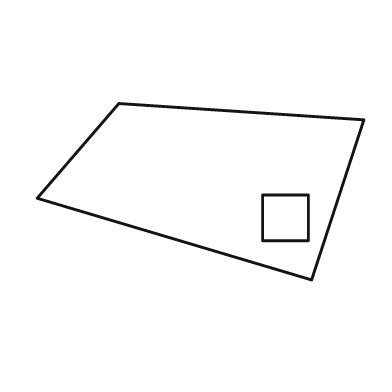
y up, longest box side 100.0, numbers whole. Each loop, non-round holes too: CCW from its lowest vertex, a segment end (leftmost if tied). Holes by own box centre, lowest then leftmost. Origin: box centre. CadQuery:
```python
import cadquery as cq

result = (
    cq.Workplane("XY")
    .moveTo(34.0, -27.0)
    .lineTo(50.0, 22.0)
    .lineTo(-25.0, 27.0)
    .lineTo(-50.0, -2.0)
    .close()
    .moveTo(19.0, -15.0)
    .lineTo(33.0, -15.0)
    .lineTo(33.0, -1.0)
    .lineTo(19.0, -1.0)
    .close()
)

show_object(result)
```